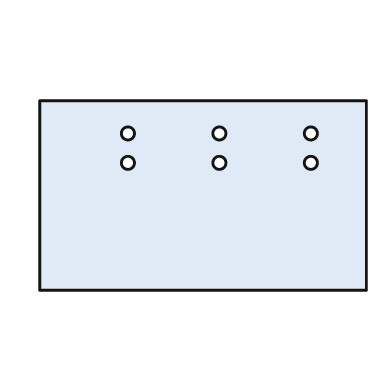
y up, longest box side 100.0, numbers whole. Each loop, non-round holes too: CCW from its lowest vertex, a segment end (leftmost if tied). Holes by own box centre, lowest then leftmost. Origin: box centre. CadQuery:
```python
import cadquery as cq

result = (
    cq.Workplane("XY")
    .moveTo(-50.0, -29.0)
    .lineTo(50.0, -29.0)
    .lineTo(50.0, 29.0)
    .lineTo(-50.0, 29.0)
    .close()
    .moveTo(-23.0, 10.0)
    .circle(2.0)
    .moveTo(5.0, 10.0)
    .circle(2.0)
    .moveTo(33.0, 10.0)
    .circle(2.0)
    .moveTo(-23.0, 19.0)
    .circle(2.0)
    .moveTo(5.0, 19.0)
    .circle(2.0)
    .moveTo(33.0, 19.0)
    .circle(2.0)
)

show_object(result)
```